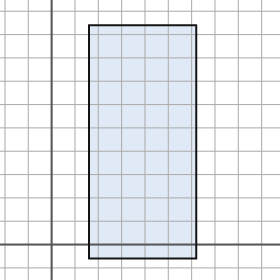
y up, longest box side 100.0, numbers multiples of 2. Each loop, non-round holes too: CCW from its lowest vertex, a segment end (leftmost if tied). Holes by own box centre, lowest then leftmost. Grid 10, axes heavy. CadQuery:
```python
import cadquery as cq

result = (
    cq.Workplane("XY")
    .moveTo(16.0, -6.0)
    .lineTo(62.0, -6.0)
    .lineTo(62.0, 94.0)
    .lineTo(16.0, 94.0)
    .close()
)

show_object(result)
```